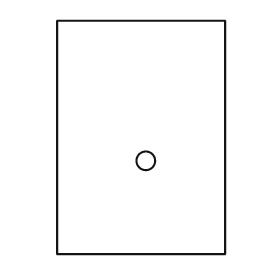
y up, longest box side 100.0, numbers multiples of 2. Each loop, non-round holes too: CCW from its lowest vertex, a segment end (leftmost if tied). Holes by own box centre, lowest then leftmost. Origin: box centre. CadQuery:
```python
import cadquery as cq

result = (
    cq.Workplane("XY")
    .moveTo(-36.0, -50.0)
    .lineTo(36.0, -50.0)
    .lineTo(36.0, 50.0)
    .lineTo(-36.0, 50.0)
    .close()
    .moveTo(2.0, -10.0)
    .circle(4.0)
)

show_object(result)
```